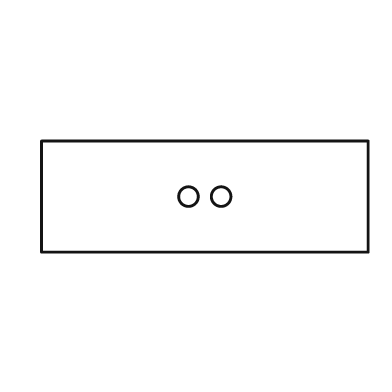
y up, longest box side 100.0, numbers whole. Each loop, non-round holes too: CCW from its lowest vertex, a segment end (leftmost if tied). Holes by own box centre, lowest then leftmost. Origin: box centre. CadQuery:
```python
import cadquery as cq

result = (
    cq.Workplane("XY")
    .moveTo(-50.0, -17.0)
    .lineTo(50.0, -17.0)
    .lineTo(50.0, 17.0)
    .lineTo(-50.0, 17.0)
    .close()
    .moveTo(-5.0, 0.0)
    .circle(3.0)
    .moveTo(5.0, 0.0)
    .circle(3.0)
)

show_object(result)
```